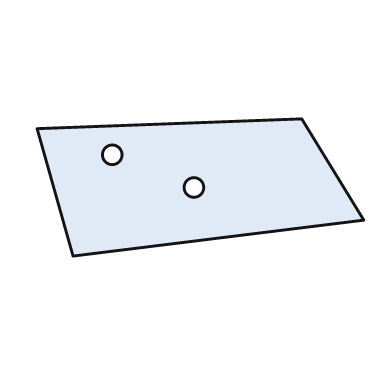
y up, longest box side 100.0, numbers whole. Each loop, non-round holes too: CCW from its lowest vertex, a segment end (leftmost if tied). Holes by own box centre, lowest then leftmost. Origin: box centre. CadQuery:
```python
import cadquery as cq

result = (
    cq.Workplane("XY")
    .moveTo(-39.0, -21.0)
    .lineTo(50.0, -10.0)
    .lineTo(31.0, 21.0)
    .lineTo(-50.0, 18.0)
    .close()
    .moveTo(-2.0, 0.0)
    .circle(3.0)
    .moveTo(-27.0, 10.0)
    .circle(3.0)
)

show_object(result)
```